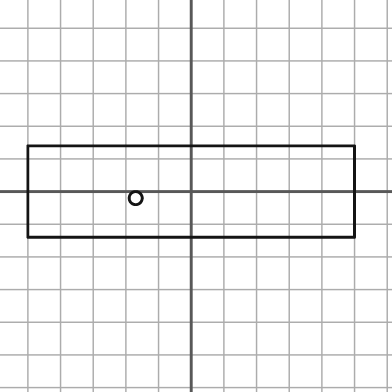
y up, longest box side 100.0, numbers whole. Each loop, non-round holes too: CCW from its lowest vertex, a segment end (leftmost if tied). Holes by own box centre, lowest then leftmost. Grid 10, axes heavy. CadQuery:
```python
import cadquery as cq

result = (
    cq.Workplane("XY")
    .moveTo(-50.0, -14.0)
    .lineTo(50.0, -14.0)
    .lineTo(50.0, 14.0)
    .lineTo(-50.0, 14.0)
    .close()
    .moveTo(-17.0, -2.0)
    .circle(2.0)
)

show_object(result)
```